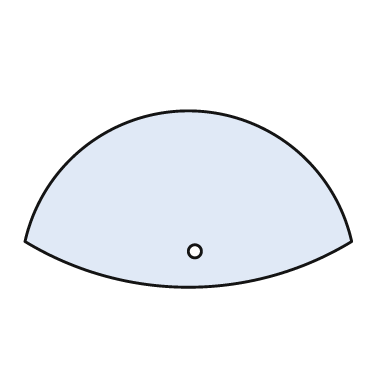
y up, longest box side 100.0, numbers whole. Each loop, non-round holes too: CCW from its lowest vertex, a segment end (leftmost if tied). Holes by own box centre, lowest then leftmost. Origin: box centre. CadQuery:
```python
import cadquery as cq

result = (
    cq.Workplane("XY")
    .moveTo(-50.0, -13.0)
    .threePointArc((0.0, -27.0), (50.0, -13.0))
    .threePointArc((0.0, 27.0), (-50.0, -13.0))
    .close()
    .moveTo(2.0, -16.0)
    .circle(2.0)
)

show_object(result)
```